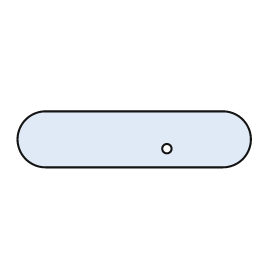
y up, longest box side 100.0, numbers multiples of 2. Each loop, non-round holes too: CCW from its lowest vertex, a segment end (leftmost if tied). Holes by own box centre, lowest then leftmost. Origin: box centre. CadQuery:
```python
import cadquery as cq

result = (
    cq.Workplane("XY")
    .moveTo(-38.0, -12.0)
    .lineTo(38.0, -12.0)
    .threePointArc((50.0, 0.0), (38.0, 12.0))
    .lineTo(-38.0, 12.0)
    .threePointArc((-50.0, 0.0), (-38.0, -12.0))
    .close()
    .moveTo(14.0, -4.0)
    .circle(2.0)
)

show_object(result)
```